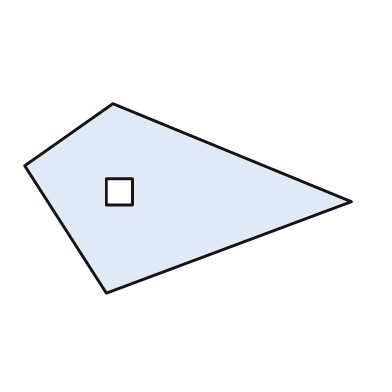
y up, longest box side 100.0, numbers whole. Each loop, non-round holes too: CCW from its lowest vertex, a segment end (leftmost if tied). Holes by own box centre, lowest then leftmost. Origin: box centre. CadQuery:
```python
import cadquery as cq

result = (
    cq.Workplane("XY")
    .moveTo(-25.0, -29.0)
    .lineTo(50.0, -1.0)
    .lineTo(-23.0, 29.0)
    .lineTo(-50.0, 10.0)
    .close()
    .moveTo(-25.0, -2.0)
    .lineTo(-17.0, -2.0)
    .lineTo(-17.0, 6.0)
    .lineTo(-25.0, 6.0)
    .close()
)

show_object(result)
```